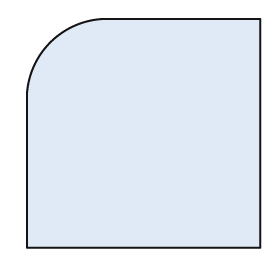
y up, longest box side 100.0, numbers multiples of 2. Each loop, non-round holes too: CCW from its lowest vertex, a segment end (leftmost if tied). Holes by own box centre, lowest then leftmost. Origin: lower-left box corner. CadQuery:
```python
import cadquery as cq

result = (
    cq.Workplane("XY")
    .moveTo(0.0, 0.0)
    .lineTo(100.0, 0.0)
    .lineTo(100.0, 98.0)
    .lineTo(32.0, 98.0)
    .threePointArc((10.0, 88.0), (0.0, 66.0))
    .close()
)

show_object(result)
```